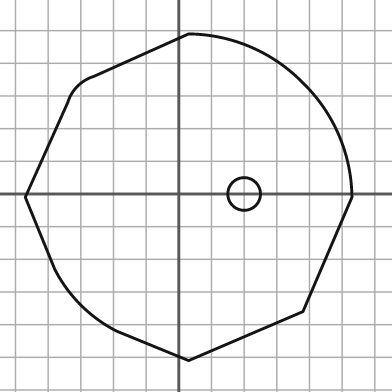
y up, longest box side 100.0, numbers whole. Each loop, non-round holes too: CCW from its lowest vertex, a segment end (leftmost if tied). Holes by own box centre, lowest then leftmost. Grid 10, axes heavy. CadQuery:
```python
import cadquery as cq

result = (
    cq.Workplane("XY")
    .moveTo(3.0, -51.0)
    .lineTo(38.0, -36.0)
    .lineTo(53.0, -1.0)
    .threePointArc((49.0, 18.0), (38.0, 34.0))
    .threePointArc((22.0, 45.0), (3.0, 49.0))
    .lineTo(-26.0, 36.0)
    .threePointArc((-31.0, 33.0), (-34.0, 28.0))
    .lineTo(-47.0, -1.0)
    .lineTo(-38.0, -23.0)
    .threePointArc((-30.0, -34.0), (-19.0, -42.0))
    .close()
    .moveTo(20.0, 0.0)
    .circle(5.0)
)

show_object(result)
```